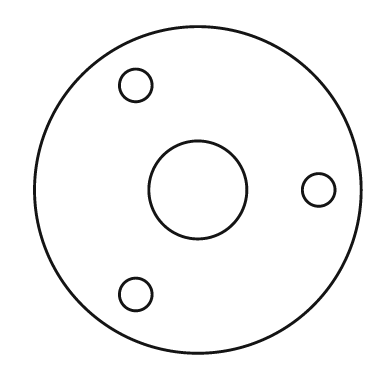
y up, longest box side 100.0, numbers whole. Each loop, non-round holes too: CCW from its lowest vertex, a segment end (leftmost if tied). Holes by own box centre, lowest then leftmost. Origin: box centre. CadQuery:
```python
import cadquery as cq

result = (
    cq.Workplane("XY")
    .moveTo(0.0, 0.0)
    .circle(50.0)
    .moveTo(-19.0, -32.0)
    .circle(5.0)
    .moveTo(0.0, 0.0)
    .circle(15.0)
    .moveTo(37.0, 0.0)
    .circle(5.0)
    .moveTo(-19.0, 32.0)
    .circle(5.0)
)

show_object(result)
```